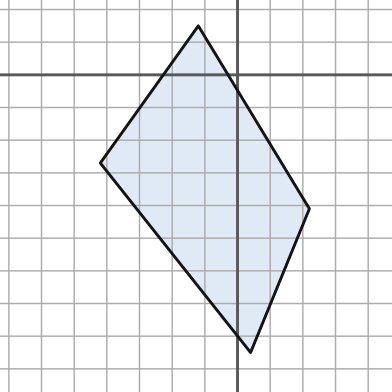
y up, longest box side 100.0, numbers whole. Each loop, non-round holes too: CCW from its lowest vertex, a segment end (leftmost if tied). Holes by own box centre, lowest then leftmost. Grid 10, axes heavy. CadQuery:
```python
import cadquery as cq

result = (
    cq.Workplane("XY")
    .moveTo(4.0, -85.0)
    .lineTo(22.0, -41.0)
    .lineTo(-12.0, 15.0)
    .lineTo(-42.0, -27.0)
    .close()
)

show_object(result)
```